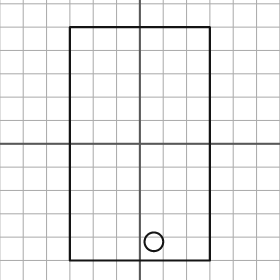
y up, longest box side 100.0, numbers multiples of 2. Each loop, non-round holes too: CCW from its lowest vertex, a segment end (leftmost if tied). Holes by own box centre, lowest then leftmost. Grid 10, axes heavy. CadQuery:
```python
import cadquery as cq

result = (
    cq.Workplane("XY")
    .moveTo(-30.0, -50.0)
    .lineTo(30.0, -50.0)
    .lineTo(30.0, 50.0)
    .lineTo(-30.0, 50.0)
    .close()
    .moveTo(6.0, -42.0)
    .circle(4.0)
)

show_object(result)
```